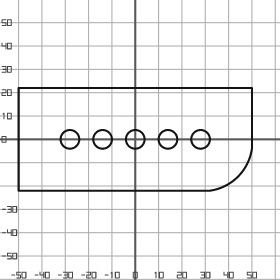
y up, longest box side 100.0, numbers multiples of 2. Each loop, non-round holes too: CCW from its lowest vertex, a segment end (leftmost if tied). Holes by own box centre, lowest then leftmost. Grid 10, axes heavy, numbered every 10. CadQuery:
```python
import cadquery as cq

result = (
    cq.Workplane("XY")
    .moveTo(-50.0, -22.0)
    .lineTo(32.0, -22.0)
    .threePointArc((44.0, -16.0), (50.0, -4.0))
    .lineTo(50.0, 22.0)
    .lineTo(-50.0, 22.0)
    .close()
    .moveTo(-28.0, 0.0)
    .circle(4.0)
    .moveTo(-14.0, 0.0)
    .circle(4.0)
    .moveTo(0.0, 0.0)
    .circle(4.0)
    .moveTo(14.0, 0.0)
    .circle(4.0)
    .moveTo(28.0, 0.0)
    .circle(4.0)
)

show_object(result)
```